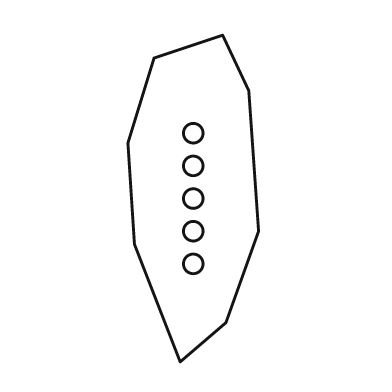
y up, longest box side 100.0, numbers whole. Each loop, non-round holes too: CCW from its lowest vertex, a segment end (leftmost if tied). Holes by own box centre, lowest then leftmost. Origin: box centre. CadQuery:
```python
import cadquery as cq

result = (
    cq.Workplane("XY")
    .moveTo(-4.0, -50.0)
    .lineTo(10.0, -38.0)
    .lineTo(20.0, -10.0)
    .lineTo(17.0, 33.0)
    .lineTo(9.0, 50.0)
    .lineTo(-12.0, 43.0)
    .lineTo(-20.0, 17.0)
    .lineTo(-18.0, -14.0)
    .close()
    .moveTo(0.0, -20.0)
    .circle(3.0)
    .moveTo(0.0, -10.0)
    .circle(3.0)
    .moveTo(0.0, 0.0)
    .circle(3.0)
    .moveTo(0.0, 10.0)
    .circle(3.0)
    .moveTo(0.0, 20.0)
    .circle(3.0)
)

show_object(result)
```